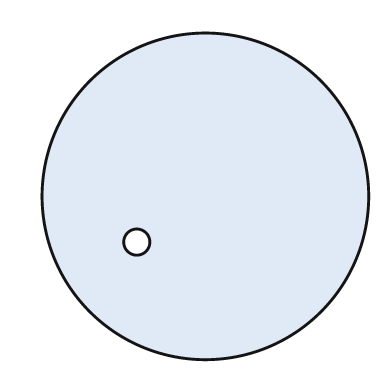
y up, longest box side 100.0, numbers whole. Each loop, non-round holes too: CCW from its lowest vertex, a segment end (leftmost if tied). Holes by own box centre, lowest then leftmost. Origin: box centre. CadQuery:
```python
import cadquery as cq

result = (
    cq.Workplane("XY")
    .moveTo(0.0, 0.0)
    .circle(50.0)
    .moveTo(-21.0, -14.0)
    .circle(4.0)
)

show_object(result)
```